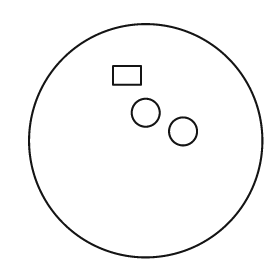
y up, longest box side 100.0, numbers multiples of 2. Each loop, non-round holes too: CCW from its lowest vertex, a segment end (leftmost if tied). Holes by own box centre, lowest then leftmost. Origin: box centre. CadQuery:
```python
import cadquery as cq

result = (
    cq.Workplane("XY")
    .moveTo(0.0, 0.0)
    .circle(50.0)
    .moveTo(16.0, 4.0)
    .circle(6.0)
    .moveTo(0.0, 12.0)
    .circle(6.0)
    .moveTo(-14.0, 24.0)
    .lineTo(-2.0, 24.0)
    .lineTo(-2.0, 32.0)
    .lineTo(-14.0, 32.0)
    .close()
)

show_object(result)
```